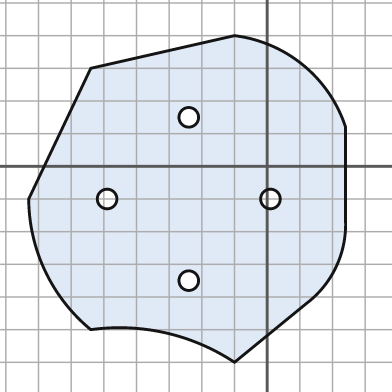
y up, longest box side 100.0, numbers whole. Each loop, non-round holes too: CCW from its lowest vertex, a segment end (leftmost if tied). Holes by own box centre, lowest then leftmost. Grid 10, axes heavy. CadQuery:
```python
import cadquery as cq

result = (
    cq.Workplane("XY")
    .moveTo(-10.0, -60.0)
    .lineTo(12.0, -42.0)
    .threePointArc((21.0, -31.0), (24.0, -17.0))
    .lineTo(24.0, 12.0)
    .threePointArc((11.0, 31.0), (-10.0, 40.0))
    .lineTo(-54.0, 30.0)
    .lineTo(-73.0, -10.0)
    .threePointArc((-68.0, -32.0), (-54.0, -50.0))
    .threePointArc((-31.0, -51.0), (-10.0, -60.0))
    .close()
    .moveTo(-24.0, -35.0)
    .circle(3.0)
    .moveTo(-49.0, -10.0)
    .circle(3.0)
    .moveTo(1.0, -10.0)
    .circle(3.0)
    .moveTo(-24.0, 15.0)
    .circle(3.0)
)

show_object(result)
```